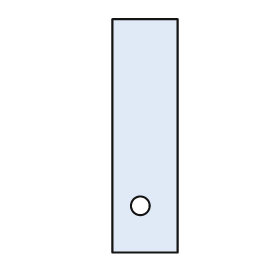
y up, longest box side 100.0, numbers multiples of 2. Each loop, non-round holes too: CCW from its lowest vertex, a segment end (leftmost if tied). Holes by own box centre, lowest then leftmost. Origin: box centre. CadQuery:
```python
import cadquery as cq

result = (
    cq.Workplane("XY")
    .moveTo(-14.0, -50.0)
    .lineTo(14.0, -50.0)
    .lineTo(14.0, 50.0)
    .lineTo(-14.0, 50.0)
    .close()
    .moveTo(-2.0, -30.0)
    .circle(4.0)
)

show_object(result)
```